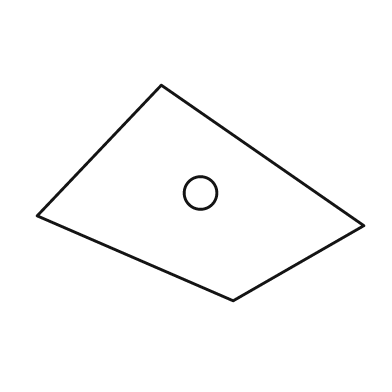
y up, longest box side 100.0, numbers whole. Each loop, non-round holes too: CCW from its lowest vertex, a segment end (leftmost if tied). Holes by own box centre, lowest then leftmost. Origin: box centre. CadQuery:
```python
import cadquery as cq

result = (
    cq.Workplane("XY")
    .moveTo(10.0, -33.0)
    .lineTo(50.0, -10.0)
    .lineTo(-12.0, 33.0)
    .lineTo(-50.0, -7.0)
    .close()
    .moveTo(0.0, 0.0)
    .circle(5.0)
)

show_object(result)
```